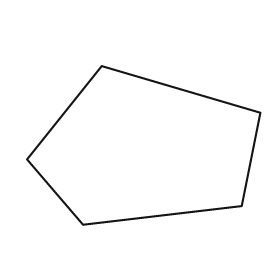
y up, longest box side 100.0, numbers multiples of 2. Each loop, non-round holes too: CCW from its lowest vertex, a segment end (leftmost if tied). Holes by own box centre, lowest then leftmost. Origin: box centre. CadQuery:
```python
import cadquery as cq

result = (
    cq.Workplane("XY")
    .moveTo(-26.0, -34.0)
    .lineTo(42.0, -26.0)
    .lineTo(50.0, 14.0)
    .lineTo(-18.0, 34.0)
    .lineTo(-50.0, -6.0)
    .close()
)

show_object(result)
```